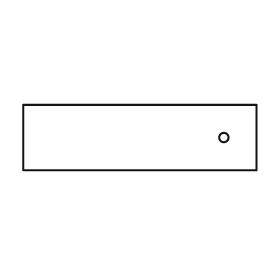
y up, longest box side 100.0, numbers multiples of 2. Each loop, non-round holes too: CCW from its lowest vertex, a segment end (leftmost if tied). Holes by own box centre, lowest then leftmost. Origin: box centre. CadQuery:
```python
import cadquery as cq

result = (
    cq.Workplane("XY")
    .moveTo(-50.0, -14.0)
    .lineTo(50.0, -14.0)
    .lineTo(50.0, 14.0)
    .lineTo(-50.0, 14.0)
    .close()
    .moveTo(36.0, 0.0)
    .circle(2.0)
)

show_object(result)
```